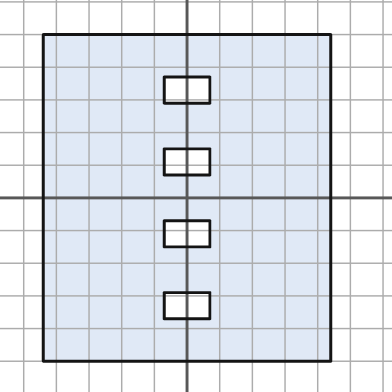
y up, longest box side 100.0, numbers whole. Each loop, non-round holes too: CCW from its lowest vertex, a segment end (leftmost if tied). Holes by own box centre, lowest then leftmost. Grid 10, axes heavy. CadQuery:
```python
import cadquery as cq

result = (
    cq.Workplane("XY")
    .moveTo(-44.0, -50.0)
    .lineTo(44.0, -50.0)
    .lineTo(44.0, 50.0)
    .lineTo(-44.0, 50.0)
    .close()
    .moveTo(-7.0, -37.0)
    .lineTo(7.0, -37.0)
    .lineTo(7.0, -29.0)
    .lineTo(-7.0, -29.0)
    .close()
    .moveTo(-7.0, -15.0)
    .lineTo(7.0, -15.0)
    .lineTo(7.0, -7.0)
    .lineTo(-7.0, -7.0)
    .close()
    .moveTo(-7.0, 7.0)
    .lineTo(7.0, 7.0)
    .lineTo(7.0, 15.0)
    .lineTo(-7.0, 15.0)
    .close()
    .moveTo(-7.0, 29.0)
    .lineTo(7.0, 29.0)
    .lineTo(7.0, 37.0)
    .lineTo(-7.0, 37.0)
    .close()
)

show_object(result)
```